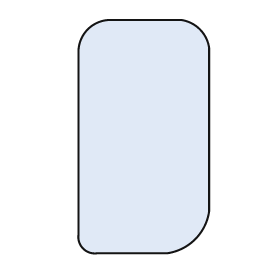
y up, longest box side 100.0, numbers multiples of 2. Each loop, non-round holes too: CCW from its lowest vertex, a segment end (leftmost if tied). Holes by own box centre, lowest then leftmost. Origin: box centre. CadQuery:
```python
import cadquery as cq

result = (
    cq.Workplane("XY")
    .moveTo(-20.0, -50.0)
    .lineTo(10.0, -50.0)
    .threePointArc((22.0, -44.0), (28.0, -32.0))
    .lineTo(28.0, 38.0)
    .threePointArc((24.0, 46.0), (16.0, 50.0))
    .lineTo(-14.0, 50.0)
    .threePointArc((-24.0, 46.0), (-28.0, 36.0))
    .lineTo(-28.0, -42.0)
    .threePointArc((-26.0, -48.0), (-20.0, -50.0))
    .close()
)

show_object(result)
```